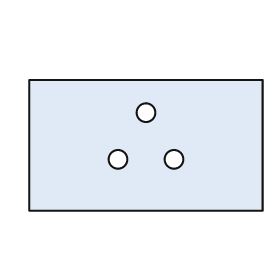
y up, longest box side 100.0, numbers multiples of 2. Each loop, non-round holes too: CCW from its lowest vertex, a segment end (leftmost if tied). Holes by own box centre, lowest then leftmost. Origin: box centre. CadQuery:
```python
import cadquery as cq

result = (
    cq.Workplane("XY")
    .moveTo(-50.0, -28.0)
    .lineTo(50.0, -28.0)
    .lineTo(50.0, 28.0)
    .lineTo(-50.0, 28.0)
    .close()
    .moveTo(-12.0, -6.0)
    .circle(4.0)
    .moveTo(12.0, -6.0)
    .circle(4.0)
    .moveTo(0.0, 14.0)
    .circle(4.0)
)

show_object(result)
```